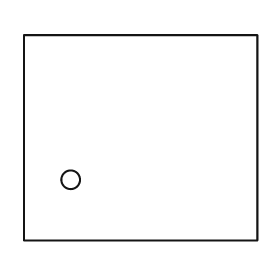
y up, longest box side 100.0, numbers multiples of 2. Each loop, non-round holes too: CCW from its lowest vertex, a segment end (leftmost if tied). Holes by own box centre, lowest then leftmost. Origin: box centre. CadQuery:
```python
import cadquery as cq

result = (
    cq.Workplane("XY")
    .moveTo(-50.0, -44.0)
    .lineTo(50.0, -44.0)
    .lineTo(50.0, 44.0)
    .lineTo(-50.0, 44.0)
    .close()
    .moveTo(-30.0, -18.0)
    .circle(4.0)
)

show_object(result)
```